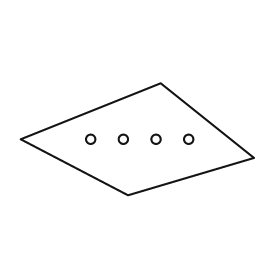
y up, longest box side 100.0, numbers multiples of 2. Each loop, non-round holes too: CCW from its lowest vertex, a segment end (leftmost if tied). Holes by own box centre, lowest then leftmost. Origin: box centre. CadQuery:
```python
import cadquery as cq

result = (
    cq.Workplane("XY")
    .moveTo(-4.0, -24.0)
    .lineTo(50.0, -8.0)
    .lineTo(10.0, 24.0)
    .lineTo(-50.0, 0.0)
    .close()
    .moveTo(-20.0, 0.0)
    .circle(2.0)
    .moveTo(-6.0, 0.0)
    .circle(2.0)
    .moveTo(8.0, 0.0)
    .circle(2.0)
    .moveTo(22.0, 0.0)
    .circle(2.0)
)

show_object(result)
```